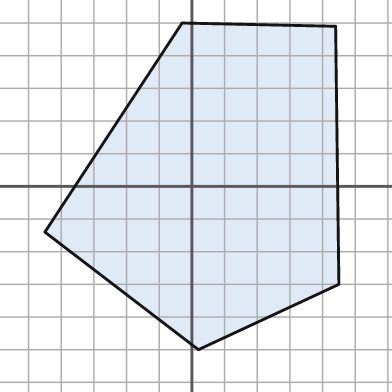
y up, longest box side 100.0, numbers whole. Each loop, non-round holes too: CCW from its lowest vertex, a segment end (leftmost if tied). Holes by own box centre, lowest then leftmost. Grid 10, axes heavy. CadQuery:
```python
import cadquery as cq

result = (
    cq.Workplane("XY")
    .moveTo(2.0, -50.0)
    .lineTo(45.0, -30.0)
    .lineTo(44.0, 49.0)
    .lineTo(-3.0, 50.0)
    .lineTo(-45.0, -14.0)
    .close()
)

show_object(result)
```